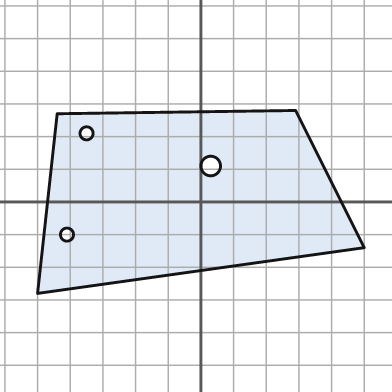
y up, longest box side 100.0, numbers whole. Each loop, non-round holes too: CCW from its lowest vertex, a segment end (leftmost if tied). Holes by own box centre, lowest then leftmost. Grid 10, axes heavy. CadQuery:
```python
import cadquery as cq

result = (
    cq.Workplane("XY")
    .moveTo(-50.0, -28.0)
    .lineTo(50.0, -14.0)
    .lineTo(29.0, 28.0)
    .lineTo(-44.0, 27.0)
    .close()
    .moveTo(-41.0, -10.0)
    .circle(2.0)
    .moveTo(3.0, 11.0)
    .circle(3.0)
    .moveTo(-35.0, 21.0)
    .circle(2.0)
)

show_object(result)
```